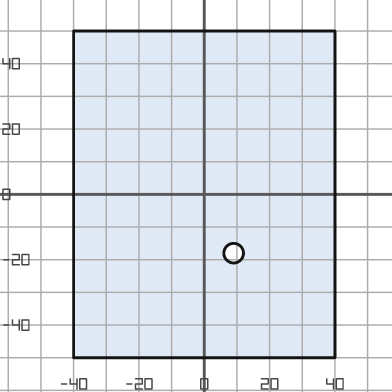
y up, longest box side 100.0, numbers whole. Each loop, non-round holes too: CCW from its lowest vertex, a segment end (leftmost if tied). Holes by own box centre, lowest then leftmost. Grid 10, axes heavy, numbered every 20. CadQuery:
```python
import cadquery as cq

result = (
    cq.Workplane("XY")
    .moveTo(-40.0, -50.0)
    .lineTo(40.0, -50.0)
    .lineTo(40.0, 50.0)
    .lineTo(-40.0, 50.0)
    .close()
    .moveTo(9.0, -18.0)
    .circle(3.0)
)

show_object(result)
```